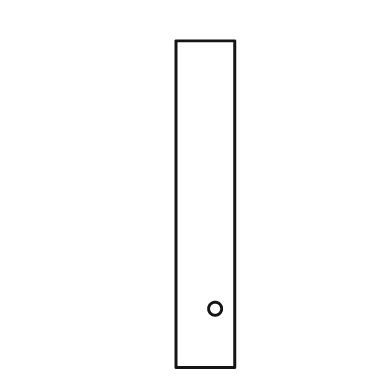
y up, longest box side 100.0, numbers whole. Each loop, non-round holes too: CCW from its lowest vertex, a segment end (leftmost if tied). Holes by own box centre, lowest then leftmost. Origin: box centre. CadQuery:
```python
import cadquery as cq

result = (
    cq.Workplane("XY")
    .moveTo(-9.0, -50.0)
    .lineTo(9.0, -50.0)
    .lineTo(9.0, 50.0)
    .lineTo(-9.0, 50.0)
    .close()
    .moveTo(3.0, -32.0)
    .circle(2.0)
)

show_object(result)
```